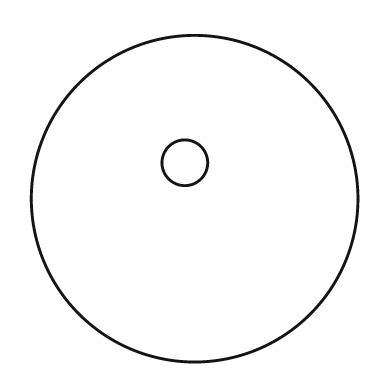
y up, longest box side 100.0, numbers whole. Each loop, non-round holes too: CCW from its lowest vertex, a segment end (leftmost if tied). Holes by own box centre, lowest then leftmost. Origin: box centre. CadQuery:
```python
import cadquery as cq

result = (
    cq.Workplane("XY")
    .moveTo(0.0, 0.0)
    .circle(50.0)
    .moveTo(-3.0, 11.0)
    .circle(7.0)
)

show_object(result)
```